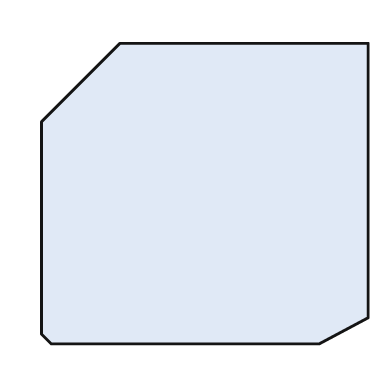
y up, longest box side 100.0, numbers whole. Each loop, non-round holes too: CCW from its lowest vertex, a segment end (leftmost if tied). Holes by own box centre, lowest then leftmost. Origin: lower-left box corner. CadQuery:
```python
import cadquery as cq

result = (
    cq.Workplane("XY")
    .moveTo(3.0, 0.0)
    .lineTo(85.0, 0.0)
    .lineTo(100.0, 8.0)
    .lineTo(100.0, 92.0)
    .lineTo(24.0, 92.0)
    .lineTo(0.0, 68.0)
    .lineTo(0.0, 3.0)
    .close()
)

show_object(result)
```